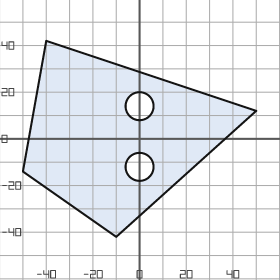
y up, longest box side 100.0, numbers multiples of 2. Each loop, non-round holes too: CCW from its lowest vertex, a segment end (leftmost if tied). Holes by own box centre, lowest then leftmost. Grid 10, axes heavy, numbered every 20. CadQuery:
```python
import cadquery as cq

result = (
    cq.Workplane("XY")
    .moveTo(-10.0, -42.0)
    .lineTo(50.0, 12.0)
    .lineTo(-40.0, 42.0)
    .lineTo(-50.0, -14.0)
    .close()
    .moveTo(0.0, -12.0)
    .circle(6.0)
    .moveTo(0.0, 14.0)
    .circle(6.0)
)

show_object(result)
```